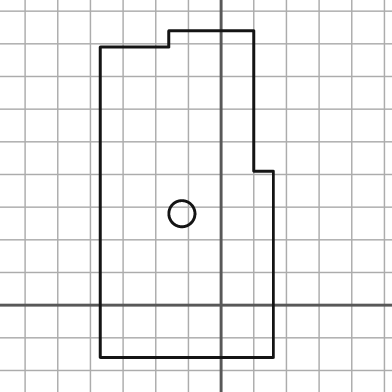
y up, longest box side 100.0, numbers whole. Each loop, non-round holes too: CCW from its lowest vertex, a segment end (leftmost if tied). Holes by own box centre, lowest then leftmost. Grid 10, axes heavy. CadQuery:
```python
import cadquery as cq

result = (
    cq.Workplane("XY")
    .moveTo(-37.0, -16.0)
    .lineTo(16.0, -16.0)
    .lineTo(16.0, 41.0)
    .lineTo(10.0, 41.0)
    .lineTo(10.0, 84.0)
    .lineTo(-16.0, 84.0)
    .lineTo(-16.0, 79.0)
    .lineTo(-37.0, 79.0)
    .close()
    .moveTo(-12.0, 28.0)
    .circle(4.0)
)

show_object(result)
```